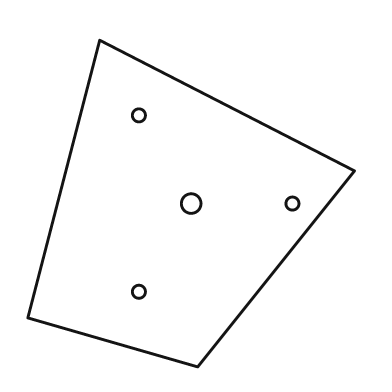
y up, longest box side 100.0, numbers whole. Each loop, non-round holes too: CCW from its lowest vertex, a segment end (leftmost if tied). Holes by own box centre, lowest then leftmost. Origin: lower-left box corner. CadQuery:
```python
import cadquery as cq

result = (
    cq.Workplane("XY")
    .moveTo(52.0, 0.0)
    .lineTo(100.0, 60.0)
    .lineTo(22.0, 100.0)
    .lineTo(0.0, 15.0)
    .close()
    .moveTo(34.0, 23.0)
    .circle(2.0)
    .moveTo(50.0, 50.0)
    .circle(3.0)
    .moveTo(81.0, 50.0)
    .circle(2.0)
    .moveTo(34.0, 77.0)
    .circle(2.0)
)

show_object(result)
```